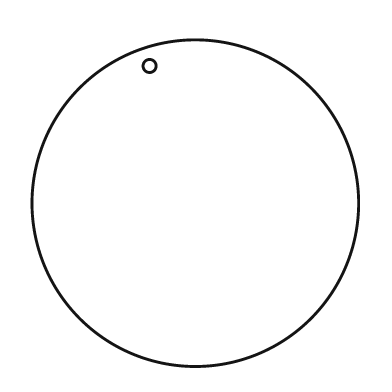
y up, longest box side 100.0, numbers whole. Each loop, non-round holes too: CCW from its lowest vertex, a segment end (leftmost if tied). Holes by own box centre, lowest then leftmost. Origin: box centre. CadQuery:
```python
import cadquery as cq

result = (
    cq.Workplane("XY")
    .moveTo(0.0, 0.0)
    .circle(50.0)
    .moveTo(-14.0, 42.0)
    .circle(2.0)
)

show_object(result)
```